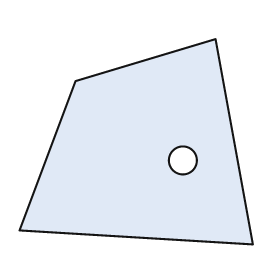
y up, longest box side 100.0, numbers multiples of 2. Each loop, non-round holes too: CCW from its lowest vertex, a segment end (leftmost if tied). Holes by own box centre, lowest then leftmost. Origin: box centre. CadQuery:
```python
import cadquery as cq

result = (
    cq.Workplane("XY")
    .moveTo(50.0, -44.0)
    .lineTo(34.0, 44.0)
    .lineTo(-26.0, 26.0)
    .lineTo(-50.0, -38.0)
    .close()
    .moveTo(20.0, -8.0)
    .circle(6.0)
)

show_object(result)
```